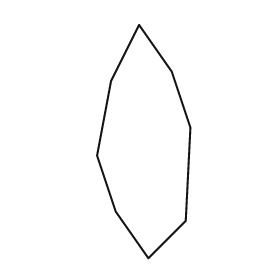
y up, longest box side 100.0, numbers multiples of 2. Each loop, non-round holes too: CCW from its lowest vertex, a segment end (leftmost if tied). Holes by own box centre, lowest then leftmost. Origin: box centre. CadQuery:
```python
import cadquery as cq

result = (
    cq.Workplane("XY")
    .moveTo(2.0, -50.0)
    .lineTo(18.0, -34.0)
    .lineTo(20.0, 6.0)
    .lineTo(12.0, 30.0)
    .lineTo(-2.0, 50.0)
    .lineTo(-14.0, 26.0)
    .lineTo(-20.0, -6.0)
    .lineTo(-12.0, -30.0)
    .close()
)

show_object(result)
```